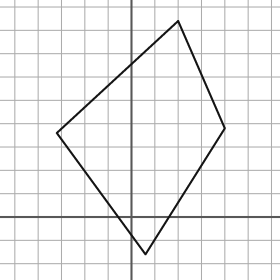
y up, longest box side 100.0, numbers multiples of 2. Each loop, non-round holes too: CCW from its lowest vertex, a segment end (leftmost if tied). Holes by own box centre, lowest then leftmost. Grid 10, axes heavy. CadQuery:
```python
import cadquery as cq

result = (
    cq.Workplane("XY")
    .moveTo(6.0, -16.0)
    .lineTo(40.0, 38.0)
    .lineTo(20.0, 84.0)
    .lineTo(-32.0, 36.0)
    .close()
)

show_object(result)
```